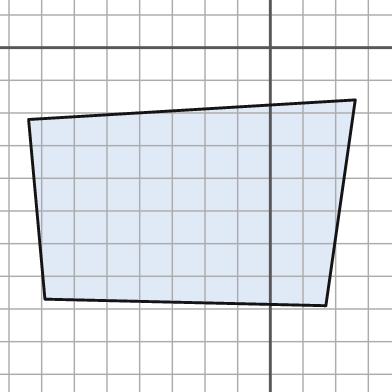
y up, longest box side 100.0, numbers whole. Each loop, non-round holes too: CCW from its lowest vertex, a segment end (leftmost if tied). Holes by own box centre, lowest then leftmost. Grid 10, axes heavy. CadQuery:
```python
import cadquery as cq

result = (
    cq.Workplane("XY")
    .moveTo(17.0, -79.0)
    .lineTo(26.0, -16.0)
    .lineTo(-74.0, -22.0)
    .lineTo(-69.0, -77.0)
    .close()
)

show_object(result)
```